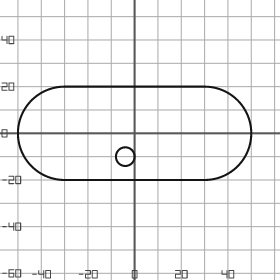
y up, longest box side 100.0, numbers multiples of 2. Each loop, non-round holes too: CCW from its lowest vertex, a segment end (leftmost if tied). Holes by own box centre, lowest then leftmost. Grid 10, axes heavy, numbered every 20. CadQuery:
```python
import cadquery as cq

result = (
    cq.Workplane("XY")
    .moveTo(-30.0, -20.0)
    .lineTo(30.0, -20.0)
    .threePointArc((50.0, 0.0), (30.0, 20.0))
    .lineTo(-30.0, 20.0)
    .threePointArc((-50.0, 0.0), (-30.0, -20.0))
    .close()
    .moveTo(-4.0, -10.0)
    .circle(4.0)
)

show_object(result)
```